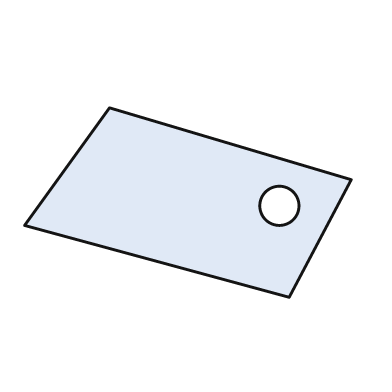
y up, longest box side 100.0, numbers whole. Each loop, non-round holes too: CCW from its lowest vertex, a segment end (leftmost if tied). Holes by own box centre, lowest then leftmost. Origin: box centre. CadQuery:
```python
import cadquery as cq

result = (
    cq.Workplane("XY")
    .moveTo(31.0, -29.0)
    .lineTo(50.0, 7.0)
    .lineTo(-24.0, 29.0)
    .lineTo(-50.0, -7.0)
    .close()
    .moveTo(28.0, -1.0)
    .circle(6.0)
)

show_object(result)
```